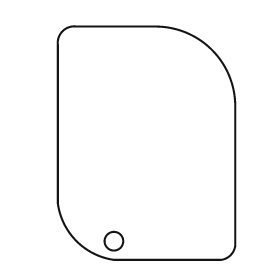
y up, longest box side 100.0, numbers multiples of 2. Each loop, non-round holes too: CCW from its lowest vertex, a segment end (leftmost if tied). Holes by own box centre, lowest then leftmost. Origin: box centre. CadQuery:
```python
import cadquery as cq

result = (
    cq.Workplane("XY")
    .moveTo(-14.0, -50.0)
    .lineTo(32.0, -50.0)
    .threePointArc((36.0, -48.0), (38.0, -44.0))
    .lineTo(38.0, 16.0)
    .threePointArc((28.0, 40.0), (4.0, 50.0))
    .lineTo(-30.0, 50.0)
    .threePointArc((-36.0, 48.0), (-38.0, 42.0))
    .lineTo(-38.0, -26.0)
    .threePointArc((-30.0, -42.0), (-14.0, -50.0))
    .close()
    .moveTo(-14.0, -42.0)
    .circle(4.0)
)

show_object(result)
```